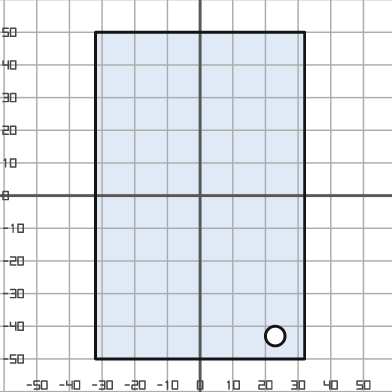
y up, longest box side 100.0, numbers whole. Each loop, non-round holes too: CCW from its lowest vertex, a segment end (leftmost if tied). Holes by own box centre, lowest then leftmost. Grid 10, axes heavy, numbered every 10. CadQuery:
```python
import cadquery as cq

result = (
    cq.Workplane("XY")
    .moveTo(-32.0, -50.0)
    .lineTo(32.0, -50.0)
    .lineTo(32.0, 50.0)
    .lineTo(-32.0, 50.0)
    .close()
    .moveTo(23.0, -43.0)
    .circle(3.0)
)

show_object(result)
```